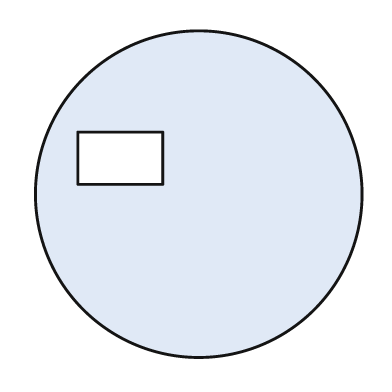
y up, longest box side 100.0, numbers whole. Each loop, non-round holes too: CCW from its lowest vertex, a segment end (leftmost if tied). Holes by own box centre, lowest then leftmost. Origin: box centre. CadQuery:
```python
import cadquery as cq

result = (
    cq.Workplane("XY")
    .moveTo(0.0, 0.0)
    .circle(50.0)
    .moveTo(-37.0, 3.0)
    .lineTo(-11.0, 3.0)
    .lineTo(-11.0, 19.0)
    .lineTo(-37.0, 19.0)
    .close()
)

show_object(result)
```